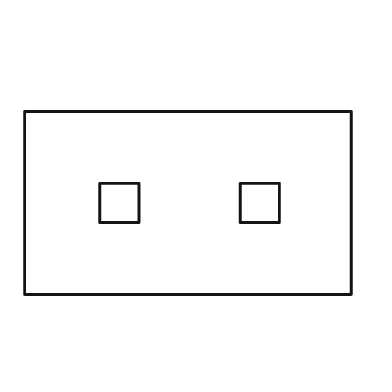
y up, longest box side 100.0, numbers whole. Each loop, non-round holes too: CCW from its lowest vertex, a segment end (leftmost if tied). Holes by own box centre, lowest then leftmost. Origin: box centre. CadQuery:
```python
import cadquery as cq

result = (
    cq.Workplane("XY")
    .moveTo(-50.0, -28.0)
    .lineTo(50.0, -28.0)
    .lineTo(50.0, 28.0)
    .lineTo(-50.0, 28.0)
    .close()
    .moveTo(-27.0, -6.0)
    .lineTo(-15.0, -6.0)
    .lineTo(-15.0, 6.0)
    .lineTo(-27.0, 6.0)
    .close()
    .moveTo(16.0, -6.0)
    .lineTo(28.0, -6.0)
    .lineTo(28.0, 6.0)
    .lineTo(16.0, 6.0)
    .close()
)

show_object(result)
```